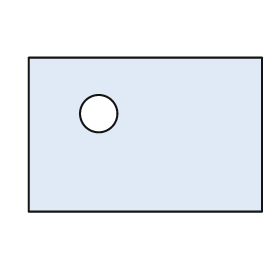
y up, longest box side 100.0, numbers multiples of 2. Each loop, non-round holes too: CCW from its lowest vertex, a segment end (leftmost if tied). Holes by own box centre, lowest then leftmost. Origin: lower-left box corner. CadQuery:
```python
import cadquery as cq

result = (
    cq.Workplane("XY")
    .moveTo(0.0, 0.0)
    .lineTo(100.0, 0.0)
    .lineTo(100.0, 66.0)
    .lineTo(0.0, 66.0)
    .close()
    .moveTo(30.0, 42.0)
    .circle(8.0)
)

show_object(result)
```